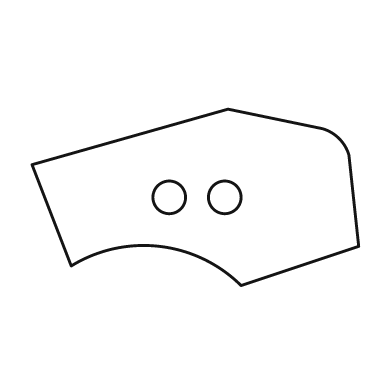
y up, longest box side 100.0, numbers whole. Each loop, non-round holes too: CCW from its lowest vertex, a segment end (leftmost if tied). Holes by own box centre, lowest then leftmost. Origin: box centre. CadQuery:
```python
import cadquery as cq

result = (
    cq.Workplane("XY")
    .moveTo(14.0, -27.0)
    .lineTo(50.0, -15.0)
    .lineTo(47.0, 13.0)
    .threePointArc((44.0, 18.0), (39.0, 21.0))
    .lineTo(10.0, 27.0)
    .lineTo(-50.0, 10.0)
    .lineTo(-38.0, -21.0)
    .threePointArc((-11.0, -15.0), (14.0, -27.0))
    .close()
    .moveTo(-8.0, 0.0)
    .circle(5.0)
    .moveTo(9.0, 0.0)
    .circle(5.0)
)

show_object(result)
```